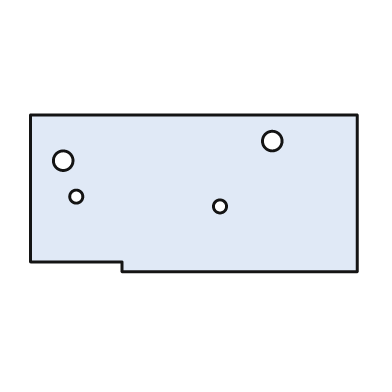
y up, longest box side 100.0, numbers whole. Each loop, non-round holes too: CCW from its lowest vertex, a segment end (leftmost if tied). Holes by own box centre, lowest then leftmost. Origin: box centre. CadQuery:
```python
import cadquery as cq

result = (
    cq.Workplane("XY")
    .moveTo(-22.0, -24.0)
    .lineTo(50.0, -24.0)
    .lineTo(50.0, 24.0)
    .lineTo(-50.0, 24.0)
    .lineTo(-50.0, -21.0)
    .lineTo(-22.0, -21.0)
    .close()
    .moveTo(8.0, -4.0)
    .circle(2.0)
    .moveTo(-36.0, -1.0)
    .circle(2.0)
    .moveTo(-40.0, 10.0)
    .circle(3.0)
    .moveTo(24.0, 16.0)
    .circle(3.0)
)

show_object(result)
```